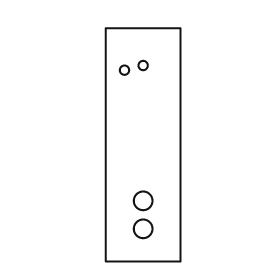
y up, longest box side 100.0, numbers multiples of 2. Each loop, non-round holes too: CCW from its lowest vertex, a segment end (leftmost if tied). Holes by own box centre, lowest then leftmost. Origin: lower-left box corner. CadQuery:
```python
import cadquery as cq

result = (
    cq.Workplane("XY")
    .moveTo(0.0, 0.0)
    .lineTo(32.0, 0.0)
    .lineTo(32.0, 100.0)
    .lineTo(0.0, 100.0)
    .close()
    .moveTo(16.0, 14.0)
    .circle(4.0)
    .moveTo(16.0, 26.0)
    .circle(4.0)
    .moveTo(8.0, 82.0)
    .circle(2.0)
    .moveTo(16.0, 84.0)
    .circle(2.0)
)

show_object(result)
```